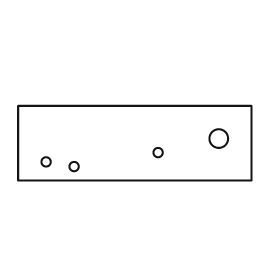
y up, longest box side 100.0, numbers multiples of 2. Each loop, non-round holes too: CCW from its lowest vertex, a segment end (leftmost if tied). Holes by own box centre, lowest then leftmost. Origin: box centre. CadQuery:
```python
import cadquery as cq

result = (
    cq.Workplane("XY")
    .moveTo(-50.0, -16.0)
    .lineTo(50.0, -16.0)
    .lineTo(50.0, 16.0)
    .lineTo(-50.0, 16.0)
    .close()
    .moveTo(-26.0, -10.0)
    .circle(2.0)
    .moveTo(-38.0, -8.0)
    .circle(2.0)
    .moveTo(10.0, -4.0)
    .circle(2.0)
    .moveTo(36.0, 2.0)
    .circle(4.0)
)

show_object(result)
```